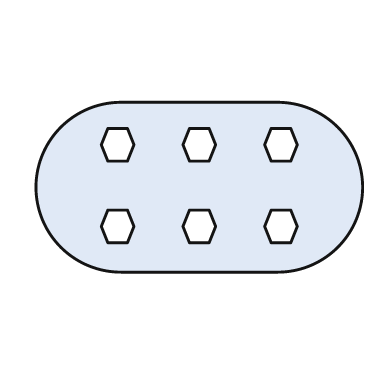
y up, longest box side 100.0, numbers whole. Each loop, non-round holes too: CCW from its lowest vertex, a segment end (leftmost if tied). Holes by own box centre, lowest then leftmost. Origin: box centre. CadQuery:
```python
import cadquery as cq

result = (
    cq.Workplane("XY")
    .moveTo(-24.0, -26.0)
    .lineTo(24.0, -26.0)
    .threePointArc((50.0, 0.0), (24.0, 26.0))
    .lineTo(-24.0, 26.0)
    .threePointArc((-50.0, 0.0), (-24.0, -26.0))
    .close()
    .moveTo(-28.0, -17.0)
    .lineTo(-22.0, -17.0)
    .lineTo(-20.0, -12.0)
    .lineTo(-22.0, -7.0)
    .lineTo(-28.0, -7.0)
    .lineTo(-30.0, -12.0)
    .close()
    .moveTo(-3.0, -17.0)
    .lineTo(3.0, -17.0)
    .lineTo(5.0, -12.0)
    .lineTo(3.0, -7.0)
    .lineTo(-3.0, -7.0)
    .lineTo(-5.0, -12.0)
    .close()
    .moveTo(22.0, -17.0)
    .lineTo(28.0, -17.0)
    .lineTo(30.0, -12.0)
    .lineTo(28.0, -7.0)
    .lineTo(22.0, -7.0)
    .lineTo(20.0, -12.0)
    .close()
    .moveTo(-28.0, 8.0)
    .lineTo(-22.0, 8.0)
    .lineTo(-20.0, 13.0)
    .lineTo(-22.0, 18.0)
    .lineTo(-28.0, 18.0)
    .lineTo(-30.0, 13.0)
    .close()
    .moveTo(-3.0, 8.0)
    .lineTo(3.0, 8.0)
    .lineTo(5.0, 13.0)
    .lineTo(3.0, 18.0)
    .lineTo(-3.0, 18.0)
    .lineTo(-5.0, 13.0)
    .close()
    .moveTo(22.0, 8.0)
    .lineTo(28.0, 8.0)
    .lineTo(30.0, 13.0)
    .lineTo(28.0, 18.0)
    .lineTo(22.0, 18.0)
    .lineTo(20.0, 13.0)
    .close()
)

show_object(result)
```